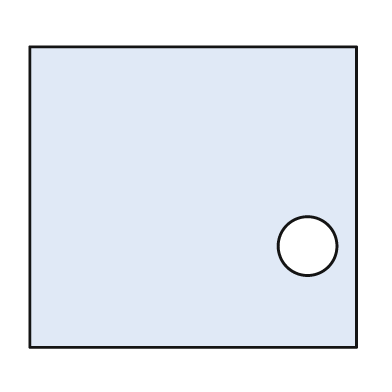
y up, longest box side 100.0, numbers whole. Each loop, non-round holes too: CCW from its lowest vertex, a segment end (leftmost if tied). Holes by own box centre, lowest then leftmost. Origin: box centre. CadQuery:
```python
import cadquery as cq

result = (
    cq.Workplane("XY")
    .moveTo(-50.0, -46.0)
    .lineTo(50.0, -46.0)
    .lineTo(50.0, 46.0)
    .lineTo(-50.0, 46.0)
    .close()
    .moveTo(35.0, -15.0)
    .circle(9.0)
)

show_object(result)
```